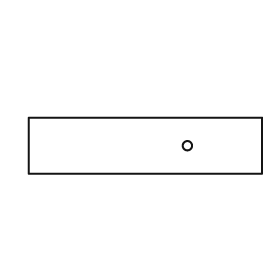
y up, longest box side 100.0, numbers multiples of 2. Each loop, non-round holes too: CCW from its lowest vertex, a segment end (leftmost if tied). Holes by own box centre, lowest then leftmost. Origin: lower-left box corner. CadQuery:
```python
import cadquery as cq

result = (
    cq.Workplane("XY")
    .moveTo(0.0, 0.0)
    .lineTo(100.0, 0.0)
    .lineTo(100.0, 24.0)
    .lineTo(0.0, 24.0)
    .close()
    .moveTo(68.0, 12.0)
    .circle(2.0)
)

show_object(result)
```